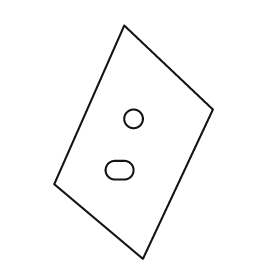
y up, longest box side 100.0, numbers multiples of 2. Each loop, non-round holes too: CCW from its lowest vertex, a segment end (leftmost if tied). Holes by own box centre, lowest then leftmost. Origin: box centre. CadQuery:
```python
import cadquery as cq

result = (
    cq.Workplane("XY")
    .moveTo(4.0, -50.0)
    .lineTo(34.0, 14.0)
    .lineTo(-4.0, 50.0)
    .lineTo(-34.0, -18.0)
    .close()
    .moveTo(-8.0, -16.0)
    .lineTo(-4.0, -16.0)
    .threePointArc((0.0, -12.0), (-4.0, -8.0))
    .lineTo(-8.0, -8.0)
    .threePointArc((-12.0, -12.0), (-8.0, -16.0))
    .close()
    .moveTo(0.0, 10.0)
    .circle(4.0)
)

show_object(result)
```